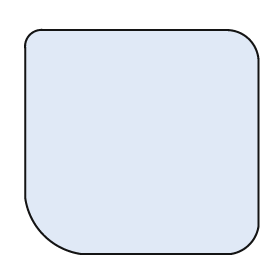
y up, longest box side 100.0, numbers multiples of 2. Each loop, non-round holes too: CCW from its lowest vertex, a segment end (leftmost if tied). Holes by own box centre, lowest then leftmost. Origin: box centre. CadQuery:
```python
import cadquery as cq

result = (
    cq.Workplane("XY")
    .moveTo(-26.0, -48.0)
    .lineTo(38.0, -48.0)
    .threePointArc((46.0, -44.0), (50.0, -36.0))
    .lineTo(50.0, 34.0)
    .threePointArc((46.0, 44.0), (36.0, 48.0))
    .lineTo(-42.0, 48.0)
    .threePointArc((-48.0, 46.0), (-50.0, 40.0))
    .lineTo(-50.0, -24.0)
    .threePointArc((-42.0, -40.0), (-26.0, -48.0))
    .close()
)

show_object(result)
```